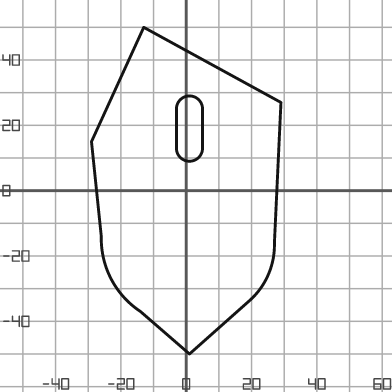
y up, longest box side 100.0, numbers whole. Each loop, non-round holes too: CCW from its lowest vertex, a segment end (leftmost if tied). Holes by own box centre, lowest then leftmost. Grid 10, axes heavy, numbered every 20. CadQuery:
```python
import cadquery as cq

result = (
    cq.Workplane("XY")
    .moveTo(1.0, -50.0)
    .lineTo(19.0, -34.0)
    .threePointArc((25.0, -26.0), (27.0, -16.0))
    .lineTo(29.0, 27.0)
    .lineTo(-13.0, 50.0)
    .lineTo(-29.0, 15.0)
    .lineTo(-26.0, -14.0)
    .threePointArc((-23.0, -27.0), (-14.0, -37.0))
    .close()
    .moveTo(-3.0, 13.0)
    .threePointArc((1.0, 9.0), (5.0, 13.0))
    .lineTo(5.0, 25.0)
    .threePointArc((1.0, 29.0), (-3.0, 25.0))
    .close()
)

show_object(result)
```